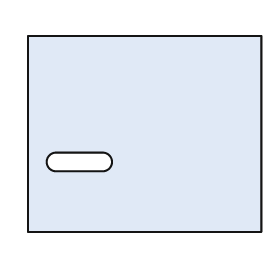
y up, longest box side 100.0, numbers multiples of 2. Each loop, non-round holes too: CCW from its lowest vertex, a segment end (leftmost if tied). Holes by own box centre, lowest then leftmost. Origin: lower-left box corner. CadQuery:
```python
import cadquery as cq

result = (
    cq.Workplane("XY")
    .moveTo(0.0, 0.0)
    .lineTo(100.0, 0.0)
    .lineTo(100.0, 84.0)
    .lineTo(0.0, 84.0)
    .close()
    .moveTo(12.0, 26.0)
    .lineTo(32.0, 26.0)
    .threePointArc((36.0, 30.0), (32.0, 34.0))
    .lineTo(12.0, 34.0)
    .threePointArc((8.0, 30.0), (12.0, 26.0))
    .close()
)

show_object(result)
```